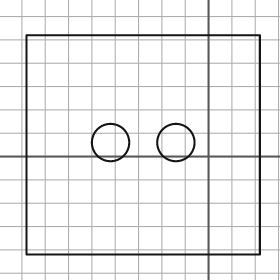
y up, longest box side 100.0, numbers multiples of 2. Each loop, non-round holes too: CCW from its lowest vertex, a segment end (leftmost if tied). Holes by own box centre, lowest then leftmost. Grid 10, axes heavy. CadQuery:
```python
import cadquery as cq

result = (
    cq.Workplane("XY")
    .moveTo(-78.0, -42.0)
    .lineTo(22.0, -42.0)
    .lineTo(22.0, 52.0)
    .lineTo(-78.0, 52.0)
    .close()
    .moveTo(-42.0, 6.0)
    .circle(8.0)
    .moveTo(-14.0, 6.0)
    .circle(8.0)
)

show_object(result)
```